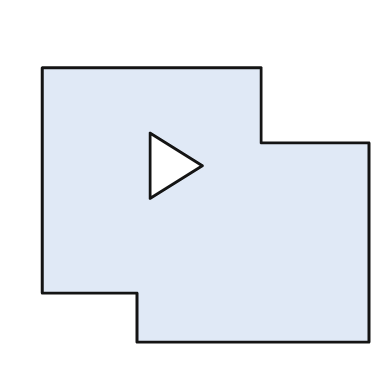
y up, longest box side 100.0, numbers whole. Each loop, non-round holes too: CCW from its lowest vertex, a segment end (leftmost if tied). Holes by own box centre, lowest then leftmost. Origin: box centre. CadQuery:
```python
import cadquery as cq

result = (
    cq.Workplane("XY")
    .moveTo(-21.0, -42.0)
    .lineTo(50.0, -42.0)
    .lineTo(50.0, 19.0)
    .lineTo(17.0, 19.0)
    .lineTo(17.0, 42.0)
    .lineTo(-50.0, 42.0)
    .lineTo(-50.0, -27.0)
    .lineTo(-21.0, -27.0)
    .close()
    .moveTo(-17.0, 2.0)
    .lineTo(-1.0, 12.0)
    .lineTo(-17.0, 22.0)
    .close()
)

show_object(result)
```